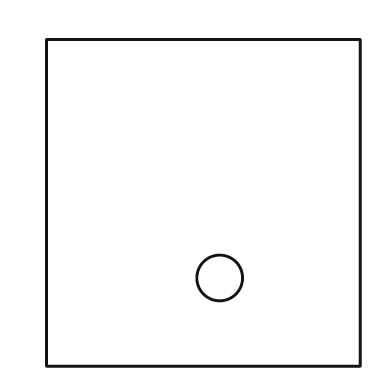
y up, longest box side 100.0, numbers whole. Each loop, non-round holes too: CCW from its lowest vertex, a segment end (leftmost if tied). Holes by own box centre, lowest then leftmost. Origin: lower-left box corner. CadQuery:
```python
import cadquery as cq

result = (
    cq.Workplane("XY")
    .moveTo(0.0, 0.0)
    .lineTo(96.0, 0.0)
    .lineTo(96.0, 100.0)
    .lineTo(0.0, 100.0)
    .close()
    .moveTo(53.0, 27.0)
    .circle(7.0)
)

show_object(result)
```